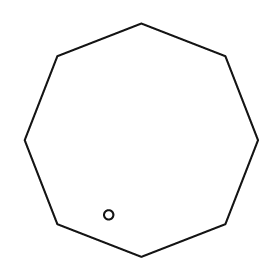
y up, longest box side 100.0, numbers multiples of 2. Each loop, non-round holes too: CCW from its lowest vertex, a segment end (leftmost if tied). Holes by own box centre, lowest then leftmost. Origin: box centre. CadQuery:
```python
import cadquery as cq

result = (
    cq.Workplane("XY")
    .moveTo(0.0, -50.0)
    .lineTo(36.0, -36.0)
    .lineTo(50.0, 0.0)
    .lineTo(36.0, 36.0)
    .lineTo(0.0, 50.0)
    .lineTo(-36.0, 36.0)
    .lineTo(-50.0, 0.0)
    .lineTo(-36.0, -36.0)
    .close()
    .moveTo(-14.0, -32.0)
    .circle(2.0)
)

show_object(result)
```